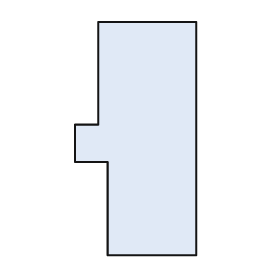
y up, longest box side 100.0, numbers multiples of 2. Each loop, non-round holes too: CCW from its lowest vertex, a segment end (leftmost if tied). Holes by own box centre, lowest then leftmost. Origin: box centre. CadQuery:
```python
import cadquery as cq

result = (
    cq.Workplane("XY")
    .moveTo(-12.0, -50.0)
    .lineTo(26.0, -50.0)
    .lineTo(26.0, 50.0)
    .lineTo(-16.0, 50.0)
    .lineTo(-16.0, 6.0)
    .lineTo(-26.0, 6.0)
    .lineTo(-26.0, -10.0)
    .lineTo(-12.0, -10.0)
    .close()
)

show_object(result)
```